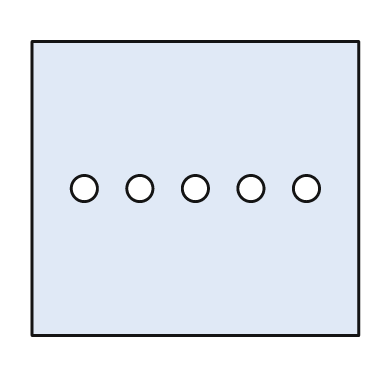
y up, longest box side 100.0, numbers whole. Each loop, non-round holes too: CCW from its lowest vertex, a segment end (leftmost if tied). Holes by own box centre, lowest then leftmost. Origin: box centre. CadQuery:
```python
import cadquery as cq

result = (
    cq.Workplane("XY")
    .moveTo(-50.0, -45.0)
    .lineTo(50.0, -45.0)
    .lineTo(50.0, 45.0)
    .lineTo(-50.0, 45.0)
    .close()
    .moveTo(-34.0, 0.0)
    .circle(4.0)
    .moveTo(-17.0, 0.0)
    .circle(4.0)
    .moveTo(0.0, 0.0)
    .circle(4.0)
    .moveTo(17.0, 0.0)
    .circle(4.0)
    .moveTo(34.0, 0.0)
    .circle(4.0)
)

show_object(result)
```